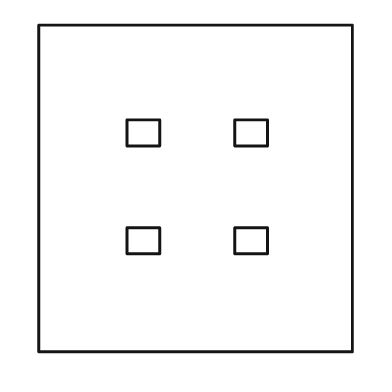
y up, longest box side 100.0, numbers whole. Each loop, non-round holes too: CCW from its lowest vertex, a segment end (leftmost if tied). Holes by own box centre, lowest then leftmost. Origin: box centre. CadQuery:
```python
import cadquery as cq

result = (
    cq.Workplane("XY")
    .moveTo(-48.0, -50.0)
    .lineTo(48.0, -50.0)
    .lineTo(48.0, 50.0)
    .lineTo(-48.0, 50.0)
    .close()
    .moveTo(-21.0, -20.0)
    .lineTo(-11.0, -20.0)
    .lineTo(-11.0, -12.0)
    .lineTo(-21.0, -12.0)
    .close()
    .moveTo(12.0, -20.0)
    .lineTo(22.0, -20.0)
    .lineTo(22.0, -12.0)
    .lineTo(12.0, -12.0)
    .close()
    .moveTo(-21.0, 13.0)
    .lineTo(-11.0, 13.0)
    .lineTo(-11.0, 21.0)
    .lineTo(-21.0, 21.0)
    .close()
    .moveTo(12.0, 13.0)
    .lineTo(22.0, 13.0)
    .lineTo(22.0, 21.0)
    .lineTo(12.0, 21.0)
    .close()
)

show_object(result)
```